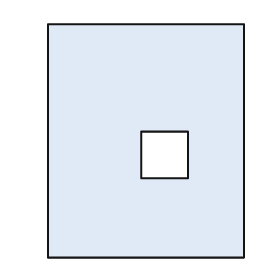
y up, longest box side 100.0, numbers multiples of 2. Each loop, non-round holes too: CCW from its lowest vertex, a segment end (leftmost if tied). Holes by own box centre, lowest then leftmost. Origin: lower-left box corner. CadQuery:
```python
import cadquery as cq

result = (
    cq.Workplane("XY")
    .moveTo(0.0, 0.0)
    .lineTo(84.0, 0.0)
    .lineTo(84.0, 100.0)
    .lineTo(0.0, 100.0)
    .close()
    .moveTo(40.0, 34.0)
    .lineTo(60.0, 34.0)
    .lineTo(60.0, 54.0)
    .lineTo(40.0, 54.0)
    .close()
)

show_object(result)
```